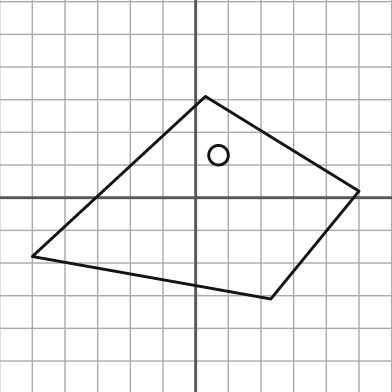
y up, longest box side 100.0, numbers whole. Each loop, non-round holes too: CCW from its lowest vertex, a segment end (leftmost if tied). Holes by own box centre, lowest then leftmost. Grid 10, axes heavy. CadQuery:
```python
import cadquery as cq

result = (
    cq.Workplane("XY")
    .moveTo(23.0, -31.0)
    .lineTo(50.0, 2.0)
    .lineTo(3.0, 31.0)
    .lineTo(-50.0, -18.0)
    .close()
    .moveTo(7.0, 13.0)
    .circle(3.0)
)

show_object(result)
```